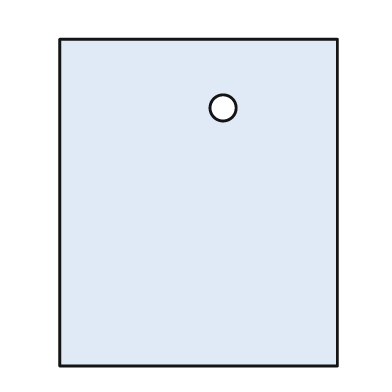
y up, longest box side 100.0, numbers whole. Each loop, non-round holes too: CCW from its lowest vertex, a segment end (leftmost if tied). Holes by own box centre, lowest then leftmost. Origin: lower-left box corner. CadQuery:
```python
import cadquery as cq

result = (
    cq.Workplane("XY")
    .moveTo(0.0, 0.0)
    .lineTo(85.0, 0.0)
    .lineTo(85.0, 100.0)
    .lineTo(0.0, 100.0)
    .close()
    .moveTo(50.0, 79.0)
    .circle(4.0)
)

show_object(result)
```